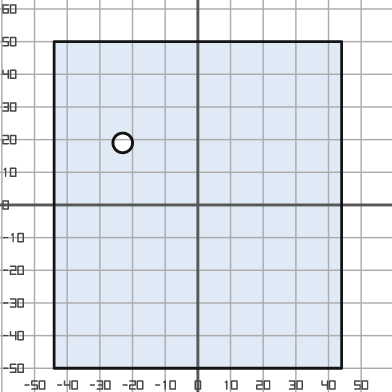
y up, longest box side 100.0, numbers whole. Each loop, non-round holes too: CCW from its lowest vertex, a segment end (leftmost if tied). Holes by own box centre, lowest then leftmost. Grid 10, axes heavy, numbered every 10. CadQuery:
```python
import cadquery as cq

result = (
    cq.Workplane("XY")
    .moveTo(-44.0, -50.0)
    .lineTo(44.0, -50.0)
    .lineTo(44.0, 50.0)
    .lineTo(-44.0, 50.0)
    .close()
    .moveTo(-23.0, 19.0)
    .circle(3.0)
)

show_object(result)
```